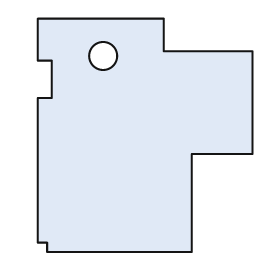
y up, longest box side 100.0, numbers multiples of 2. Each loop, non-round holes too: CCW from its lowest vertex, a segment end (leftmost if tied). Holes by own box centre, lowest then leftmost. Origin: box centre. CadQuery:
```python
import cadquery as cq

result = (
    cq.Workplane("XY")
    .moveTo(-42.0, -50.0)
    .lineTo(20.0, -50.0)
    .lineTo(20.0, -8.0)
    .lineTo(46.0, -8.0)
    .lineTo(46.0, 36.0)
    .lineTo(8.0, 36.0)
    .lineTo(8.0, 50.0)
    .lineTo(-46.0, 50.0)
    .lineTo(-46.0, 32.0)
    .lineTo(-40.0, 32.0)
    .lineTo(-40.0, 16.0)
    .lineTo(-46.0, 16.0)
    .lineTo(-46.0, -46.0)
    .lineTo(-42.0, -46.0)
    .close()
    .moveTo(-18.0, 34.0)
    .circle(6.0)
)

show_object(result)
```